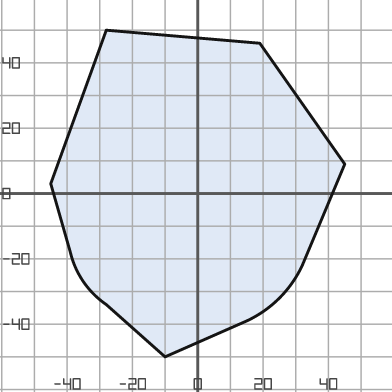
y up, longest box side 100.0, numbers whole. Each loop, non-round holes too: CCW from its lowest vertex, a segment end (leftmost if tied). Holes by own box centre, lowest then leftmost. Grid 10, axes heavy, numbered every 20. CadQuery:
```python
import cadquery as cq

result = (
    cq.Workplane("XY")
    .moveTo(-10.0, -50.0)
    .lineTo(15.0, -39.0)
    .threePointArc((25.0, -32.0), (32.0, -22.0))
    .lineTo(45.0, 9.0)
    .lineTo(19.0, 46.0)
    .lineTo(-28.0, 50.0)
    .lineTo(-45.0, 3.0)
    .lineTo(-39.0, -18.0)
    .threePointArc((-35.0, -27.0), (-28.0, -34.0))
    .close()
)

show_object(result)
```